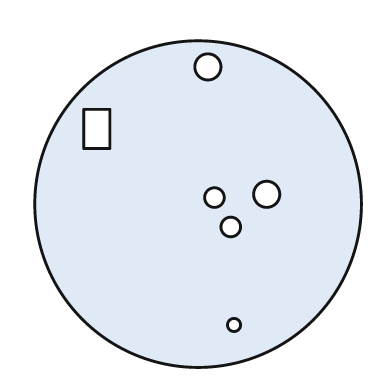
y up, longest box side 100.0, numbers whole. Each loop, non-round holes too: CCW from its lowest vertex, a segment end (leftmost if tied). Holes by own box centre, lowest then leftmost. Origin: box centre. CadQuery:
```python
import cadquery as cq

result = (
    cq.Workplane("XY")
    .moveTo(0.0, 0.0)
    .circle(50.0)
    .moveTo(11.0, -37.0)
    .circle(2.0)
    .moveTo(10.0, -7.0)
    .circle(3.0)
    .moveTo(5.0, 2.0)
    .circle(3.0)
    .moveTo(21.0, 3.0)
    .circle(4.0)
    .moveTo(-35.0, 17.0)
    .lineTo(-27.0, 17.0)
    .lineTo(-27.0, 29.0)
    .lineTo(-35.0, 29.0)
    .close()
    .moveTo(3.0, 42.0)
    .circle(4.0)
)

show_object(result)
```